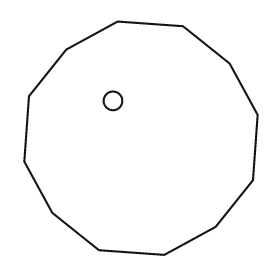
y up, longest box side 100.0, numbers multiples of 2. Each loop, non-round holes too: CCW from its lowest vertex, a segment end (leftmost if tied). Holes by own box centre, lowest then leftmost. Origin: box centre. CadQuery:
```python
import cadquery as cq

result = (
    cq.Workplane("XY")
    .moveTo(10.0, -50.0)
    .lineTo(32.0, -38.0)
    .lineTo(48.0, -18.0)
    .lineTo(50.0, 10.0)
    .lineTo(38.0, 32.0)
    .lineTo(18.0, 48.0)
    .lineTo(-10.0, 50.0)
    .lineTo(-32.0, 38.0)
    .lineTo(-48.0, 18.0)
    .lineTo(-50.0, -10.0)
    .lineTo(-38.0, -32.0)
    .lineTo(-18.0, -48.0)
    .close()
    .moveTo(-12.0, 16.0)
    .circle(4.0)
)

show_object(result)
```